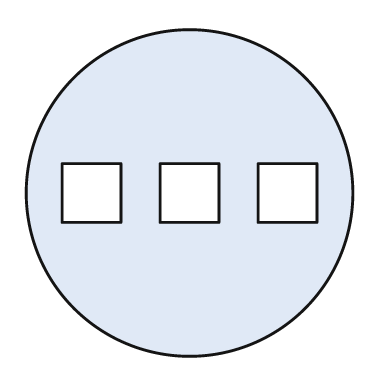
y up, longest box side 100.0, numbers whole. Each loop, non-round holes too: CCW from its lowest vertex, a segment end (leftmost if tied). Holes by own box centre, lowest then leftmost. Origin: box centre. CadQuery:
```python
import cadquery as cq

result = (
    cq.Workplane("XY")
    .moveTo(0.0, 0.0)
    .circle(50.0)
    .moveTo(-39.0, -9.0)
    .lineTo(-21.0, -9.0)
    .lineTo(-21.0, 9.0)
    .lineTo(-39.0, 9.0)
    .close()
    .moveTo(-9.0, -9.0)
    .lineTo(9.0, -9.0)
    .lineTo(9.0, 9.0)
    .lineTo(-9.0, 9.0)
    .close()
    .moveTo(21.0, -9.0)
    .lineTo(39.0, -9.0)
    .lineTo(39.0, 9.0)
    .lineTo(21.0, 9.0)
    .close()
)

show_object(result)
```